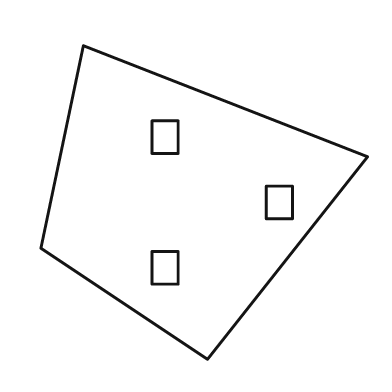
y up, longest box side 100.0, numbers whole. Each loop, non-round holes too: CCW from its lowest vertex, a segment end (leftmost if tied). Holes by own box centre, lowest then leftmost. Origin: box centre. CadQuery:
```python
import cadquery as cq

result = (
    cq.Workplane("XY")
    .moveTo(1.0, -48.0)
    .lineTo(50.0, 14.0)
    .lineTo(-37.0, 48.0)
    .lineTo(-50.0, -14.0)
    .close()
    .moveTo(-16.0, -25.0)
    .lineTo(-8.0, -25.0)
    .lineTo(-8.0, -15.0)
    .lineTo(-16.0, -15.0)
    .close()
    .moveTo(19.0, -5.0)
    .lineTo(27.0, -5.0)
    .lineTo(27.0, 5.0)
    .lineTo(19.0, 5.0)
    .close()
    .moveTo(-16.0, 15.0)
    .lineTo(-8.0, 15.0)
    .lineTo(-8.0, 25.0)
    .lineTo(-16.0, 25.0)
    .close()
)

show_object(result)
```